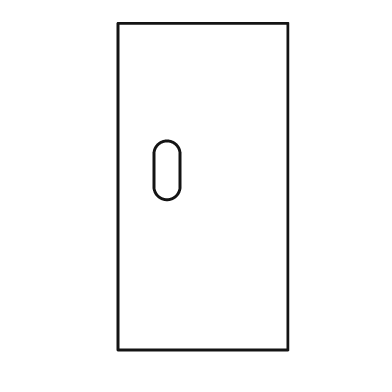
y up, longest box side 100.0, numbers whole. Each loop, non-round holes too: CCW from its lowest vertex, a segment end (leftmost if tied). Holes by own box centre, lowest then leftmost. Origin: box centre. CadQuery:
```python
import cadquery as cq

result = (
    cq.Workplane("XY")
    .moveTo(-26.0, -50.0)
    .lineTo(26.0, -50.0)
    .lineTo(26.0, 50.0)
    .lineTo(-26.0, 50.0)
    .close()
    .moveTo(-15.0, 0.0)
    .threePointArc((-11.0, -4.0), (-7.0, 0.0))
    .lineTo(-7.0, 10.0)
    .threePointArc((-11.0, 14.0), (-15.0, 10.0))
    .close()
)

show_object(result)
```